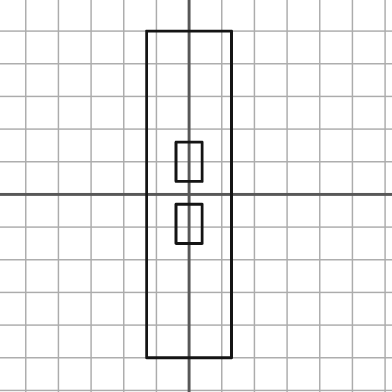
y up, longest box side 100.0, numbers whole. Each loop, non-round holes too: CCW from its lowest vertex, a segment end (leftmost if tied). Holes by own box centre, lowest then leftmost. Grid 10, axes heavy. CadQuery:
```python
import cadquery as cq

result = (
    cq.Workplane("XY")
    .moveTo(-13.0, -50.0)
    .lineTo(13.0, -50.0)
    .lineTo(13.0, 50.0)
    .lineTo(-13.0, 50.0)
    .close()
    .moveTo(-4.0, -15.0)
    .lineTo(4.0, -15.0)
    .lineTo(4.0, -3.0)
    .lineTo(-4.0, -3.0)
    .close()
    .moveTo(-4.0, 4.0)
    .lineTo(4.0, 4.0)
    .lineTo(4.0, 16.0)
    .lineTo(-4.0, 16.0)
    .close()
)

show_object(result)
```